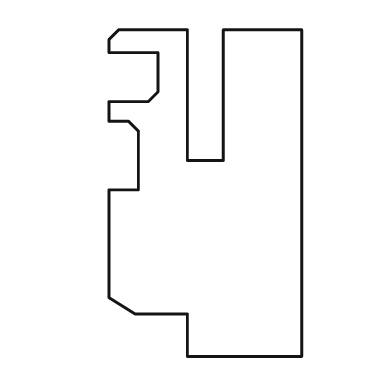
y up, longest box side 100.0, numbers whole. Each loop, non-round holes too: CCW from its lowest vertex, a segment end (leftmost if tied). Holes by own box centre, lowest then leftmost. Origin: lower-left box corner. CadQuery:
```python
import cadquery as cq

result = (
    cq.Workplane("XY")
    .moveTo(24.0, 0.0)
    .lineTo(59.0, 0.0)
    .lineTo(59.0, 100.0)
    .lineTo(35.0, 100.0)
    .lineTo(35.0, 60.0)
    .lineTo(24.0, 60.0)
    .lineTo(24.0, 100.0)
    .lineTo(3.0, 100.0)
    .lineTo(0.0, 97.0)
    .lineTo(0.0, 93.0)
    .lineTo(15.0, 93.0)
    .lineTo(15.0, 81.0)
    .lineTo(12.0, 78.0)
    .lineTo(0.0, 78.0)
    .lineTo(0.0, 72.0)
    .lineTo(6.0, 72.0)
    .lineTo(9.0, 69.0)
    .lineTo(9.0, 51.0)
    .lineTo(0.0, 51.0)
    .lineTo(0.0, 18.0)
    .lineTo(8.0, 13.0)
    .lineTo(24.0, 13.0)
    .close()
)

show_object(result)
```